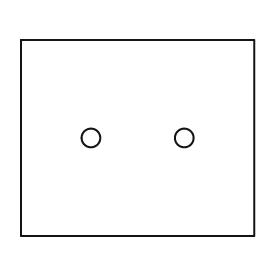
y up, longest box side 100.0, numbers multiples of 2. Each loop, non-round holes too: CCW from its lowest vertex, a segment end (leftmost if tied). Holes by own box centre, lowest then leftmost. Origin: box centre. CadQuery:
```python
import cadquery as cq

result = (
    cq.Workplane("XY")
    .moveTo(-50.0, -42.0)
    .lineTo(50.0, -42.0)
    .lineTo(50.0, 42.0)
    .lineTo(-50.0, 42.0)
    .close()
    .moveTo(-20.0, 0.0)
    .circle(4.0)
    .moveTo(20.0, 0.0)
    .circle(4.0)
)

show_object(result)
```